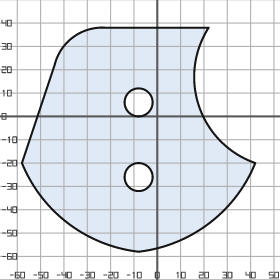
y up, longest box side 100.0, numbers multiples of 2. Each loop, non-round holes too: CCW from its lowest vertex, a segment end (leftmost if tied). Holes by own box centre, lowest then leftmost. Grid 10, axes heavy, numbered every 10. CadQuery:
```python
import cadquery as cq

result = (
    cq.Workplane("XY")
    .moveTo(-8.0, -58.0)
    .threePointArc((22.0, -46.0), (42.0, -20.0))
    .threePointArc((18.0, 4.0), (22.0, 38.0))
    .lineTo(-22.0, 38.0)
    .threePointArc((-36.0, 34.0), (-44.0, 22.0))
    .lineTo(-58.0, -20.0)
    .threePointArc((-38.0, -46.0), (-8.0, -58.0))
    .close()
    .moveTo(-8.0, -26.0)
    .circle(6.0)
    .moveTo(-8.0, 6.0)
    .circle(6.0)
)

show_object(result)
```